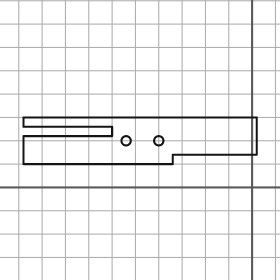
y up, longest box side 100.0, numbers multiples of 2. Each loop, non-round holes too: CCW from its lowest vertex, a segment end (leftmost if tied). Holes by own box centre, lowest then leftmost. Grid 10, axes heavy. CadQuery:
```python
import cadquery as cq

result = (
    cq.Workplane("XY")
    .moveTo(-98.0, 10.0)
    .lineTo(-34.0, 10.0)
    .lineTo(-34.0, 14.0)
    .lineTo(2.0, 14.0)
    .lineTo(2.0, 30.0)
    .lineTo(-98.0, 30.0)
    .lineTo(-98.0, 26.0)
    .lineTo(-60.0, 26.0)
    .lineTo(-60.0, 22.0)
    .lineTo(-98.0, 22.0)
    .close()
    .moveTo(-54.0, 20.0)
    .circle(2.0)
    .moveTo(-40.0, 20.0)
    .circle(2.0)
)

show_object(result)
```